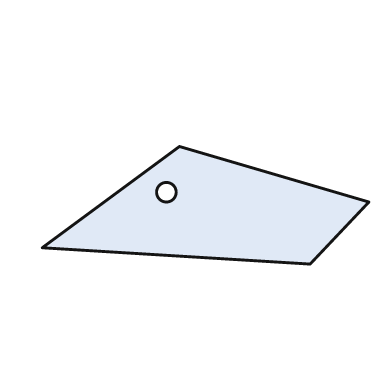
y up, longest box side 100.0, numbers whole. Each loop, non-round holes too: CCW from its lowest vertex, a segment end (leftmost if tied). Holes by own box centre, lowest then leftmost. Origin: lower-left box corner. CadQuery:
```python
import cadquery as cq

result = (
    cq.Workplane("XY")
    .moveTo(82.0, 0.0)
    .lineTo(100.0, 19.0)
    .lineTo(42.0, 36.0)
    .lineTo(0.0, 5.0)
    .close()
    .moveTo(38.0, 22.0)
    .circle(3.0)
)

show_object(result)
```